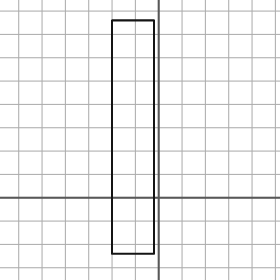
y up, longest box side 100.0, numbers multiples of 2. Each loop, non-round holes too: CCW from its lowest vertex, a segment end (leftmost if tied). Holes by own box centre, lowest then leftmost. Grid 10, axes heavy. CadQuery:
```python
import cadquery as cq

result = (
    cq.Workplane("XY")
    .moveTo(-20.0, -24.0)
    .lineTo(-2.0, -24.0)
    .lineTo(-2.0, 76.0)
    .lineTo(-20.0, 76.0)
    .close()
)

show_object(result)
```